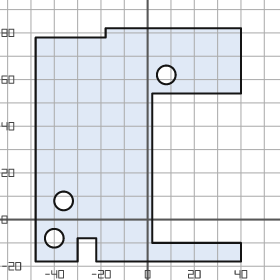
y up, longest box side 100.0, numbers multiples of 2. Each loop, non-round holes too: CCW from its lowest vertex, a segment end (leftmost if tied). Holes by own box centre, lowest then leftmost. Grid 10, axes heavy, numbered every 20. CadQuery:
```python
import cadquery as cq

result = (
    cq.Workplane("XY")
    .moveTo(-48.0, -18.0)
    .lineTo(-30.0, -18.0)
    .lineTo(-30.0, -8.0)
    .lineTo(-22.0, -8.0)
    .lineTo(-22.0, -18.0)
    .lineTo(40.0, -18.0)
    .lineTo(40.0, -10.0)
    .lineTo(2.0, -10.0)
    .lineTo(2.0, 54.0)
    .lineTo(40.0, 54.0)
    .lineTo(40.0, 82.0)
    .lineTo(-18.0, 82.0)
    .lineTo(-18.0, 78.0)
    .lineTo(-48.0, 78.0)
    .close()
    .moveTo(-40.0, -8.0)
    .circle(4.0)
    .moveTo(-36.0, 8.0)
    .circle(4.0)
    .moveTo(8.0, 62.0)
    .circle(4.0)
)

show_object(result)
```